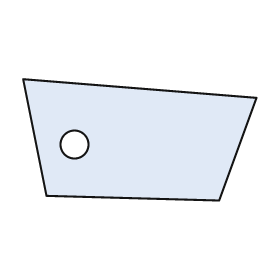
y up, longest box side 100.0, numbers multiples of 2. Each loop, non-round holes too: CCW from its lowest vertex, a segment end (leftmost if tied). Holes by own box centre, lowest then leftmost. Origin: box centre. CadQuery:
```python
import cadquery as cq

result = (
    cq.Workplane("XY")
    .moveTo(34.0, -26.0)
    .lineTo(50.0, 18.0)
    .lineTo(-50.0, 26.0)
    .lineTo(-40.0, -24.0)
    .close()
    .moveTo(-28.0, -2.0)
    .circle(6.0)
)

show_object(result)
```